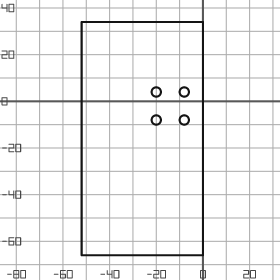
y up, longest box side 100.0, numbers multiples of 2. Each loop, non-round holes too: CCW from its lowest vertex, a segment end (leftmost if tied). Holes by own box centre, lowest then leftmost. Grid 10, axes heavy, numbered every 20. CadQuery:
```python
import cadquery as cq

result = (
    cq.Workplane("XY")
    .moveTo(-52.0, -66.0)
    .lineTo(0.0, -66.0)
    .lineTo(0.0, 34.0)
    .lineTo(-52.0, 34.0)
    .close()
    .moveTo(-20.0, -8.0)
    .circle(2.0)
    .moveTo(-8.0, -8.0)
    .circle(2.0)
    .moveTo(-20.0, 4.0)
    .circle(2.0)
    .moveTo(-8.0, 4.0)
    .circle(2.0)
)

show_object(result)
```